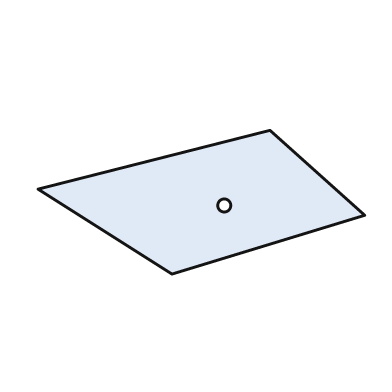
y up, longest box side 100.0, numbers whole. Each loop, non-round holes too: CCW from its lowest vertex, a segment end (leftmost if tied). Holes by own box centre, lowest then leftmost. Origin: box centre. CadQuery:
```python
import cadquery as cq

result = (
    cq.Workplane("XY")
    .moveTo(-9.0, -22.0)
    .lineTo(50.0, -4.0)
    .lineTo(21.0, 22.0)
    .lineTo(-50.0, 4.0)
    .close()
    .moveTo(7.0, -1.0)
    .circle(2.0)
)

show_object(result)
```